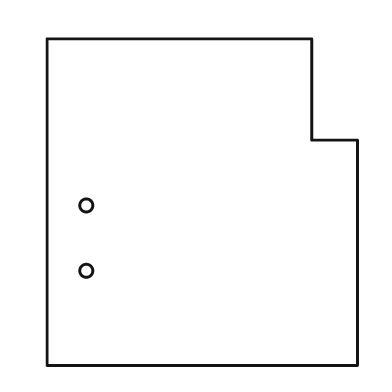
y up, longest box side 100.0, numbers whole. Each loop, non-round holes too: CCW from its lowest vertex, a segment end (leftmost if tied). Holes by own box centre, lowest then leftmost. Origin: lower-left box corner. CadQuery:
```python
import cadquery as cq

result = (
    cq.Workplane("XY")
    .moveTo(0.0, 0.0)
    .lineTo(95.0, 0.0)
    .lineTo(95.0, 69.0)
    .lineTo(81.0, 69.0)
    .lineTo(81.0, 100.0)
    .lineTo(0.0, 100.0)
    .close()
    .moveTo(12.0, 29.0)
    .circle(2.0)
    .moveTo(12.0, 49.0)
    .circle(2.0)
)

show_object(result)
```